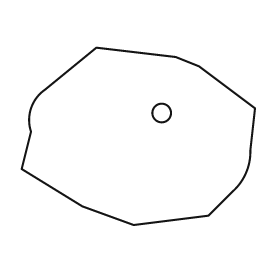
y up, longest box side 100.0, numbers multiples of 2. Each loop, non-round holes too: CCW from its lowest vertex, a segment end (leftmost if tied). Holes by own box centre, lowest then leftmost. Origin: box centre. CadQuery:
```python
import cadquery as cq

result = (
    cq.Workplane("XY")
    .moveTo(-2.0, -38.0)
    .lineTo(30.0, -34.0)
    .lineTo(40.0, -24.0)
    .threePointArc((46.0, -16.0), (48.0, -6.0))
    .lineTo(50.0, 12.0)
    .lineTo(26.0, 30.0)
    .lineTo(16.0, 34.0)
    .lineTo(-18.0, 38.0)
    .lineTo(-40.0, 20.0)
    .threePointArc((-46.0, 12.0), (-46.0, 2.0))
    .lineTo(-50.0, -14.0)
    .lineTo(-24.0, -30.0)
    .close()
    .moveTo(10.0, 10.0)
    .circle(4.0)
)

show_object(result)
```